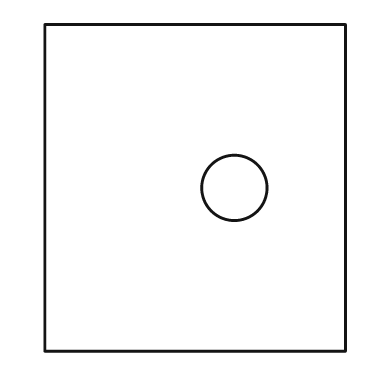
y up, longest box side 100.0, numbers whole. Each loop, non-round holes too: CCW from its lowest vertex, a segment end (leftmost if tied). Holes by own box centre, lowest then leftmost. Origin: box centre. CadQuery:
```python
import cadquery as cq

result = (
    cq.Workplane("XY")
    .moveTo(-46.0, -50.0)
    .lineTo(46.0, -50.0)
    .lineTo(46.0, 50.0)
    .lineTo(-46.0, 50.0)
    .close()
    .moveTo(12.0, 0.0)
    .circle(10.0)
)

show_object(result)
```